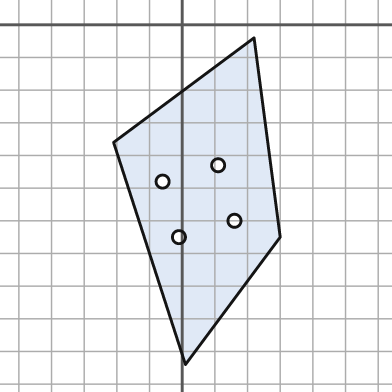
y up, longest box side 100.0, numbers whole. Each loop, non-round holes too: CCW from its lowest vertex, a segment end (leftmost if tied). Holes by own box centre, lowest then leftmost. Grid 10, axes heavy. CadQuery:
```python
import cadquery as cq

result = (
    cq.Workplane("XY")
    .moveTo(1.0, -104.0)
    .lineTo(30.0, -65.0)
    .lineTo(22.0, -4.0)
    .lineTo(-21.0, -36.0)
    .close()
    .moveTo(-1.0, -65.0)
    .circle(2.0)
    .moveTo(16.0, -60.0)
    .circle(2.0)
    .moveTo(-6.0, -48.0)
    .circle(2.0)
    .moveTo(11.0, -43.0)
    .circle(2.0)
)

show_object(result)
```